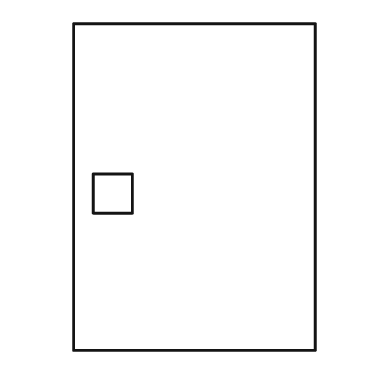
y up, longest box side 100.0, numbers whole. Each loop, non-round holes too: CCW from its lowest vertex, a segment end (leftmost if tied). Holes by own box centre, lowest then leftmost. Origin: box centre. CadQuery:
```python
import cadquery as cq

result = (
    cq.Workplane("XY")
    .moveTo(-37.0, -50.0)
    .lineTo(37.0, -50.0)
    .lineTo(37.0, 50.0)
    .lineTo(-37.0, 50.0)
    .close()
    .moveTo(-31.0, -8.0)
    .lineTo(-19.0, -8.0)
    .lineTo(-19.0, 4.0)
    .lineTo(-31.0, 4.0)
    .close()
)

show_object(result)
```